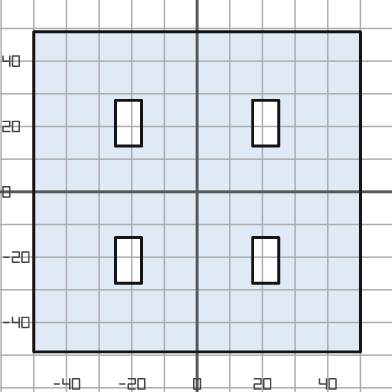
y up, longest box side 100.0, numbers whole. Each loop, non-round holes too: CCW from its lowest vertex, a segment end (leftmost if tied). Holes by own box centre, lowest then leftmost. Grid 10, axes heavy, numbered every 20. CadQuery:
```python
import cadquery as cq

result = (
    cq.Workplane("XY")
    .moveTo(-50.0, -49.0)
    .lineTo(50.0, -49.0)
    .lineTo(50.0, 49.0)
    .lineTo(-50.0, 49.0)
    .close()
    .moveTo(-25.0, -28.0)
    .lineTo(-17.0, -28.0)
    .lineTo(-17.0, -14.0)
    .lineTo(-25.0, -14.0)
    .close()
    .moveTo(17.0, -28.0)
    .lineTo(25.0, -28.0)
    .lineTo(25.0, -14.0)
    .lineTo(17.0, -14.0)
    .close()
    .moveTo(-25.0, 14.0)
    .lineTo(-17.0, 14.0)
    .lineTo(-17.0, 28.0)
    .lineTo(-25.0, 28.0)
    .close()
    .moveTo(17.0, 14.0)
    .lineTo(25.0, 14.0)
    .lineTo(25.0, 28.0)
    .lineTo(17.0, 28.0)
    .close()
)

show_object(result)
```